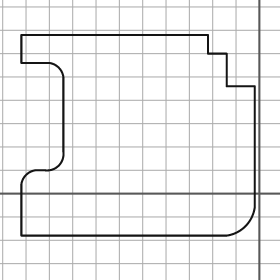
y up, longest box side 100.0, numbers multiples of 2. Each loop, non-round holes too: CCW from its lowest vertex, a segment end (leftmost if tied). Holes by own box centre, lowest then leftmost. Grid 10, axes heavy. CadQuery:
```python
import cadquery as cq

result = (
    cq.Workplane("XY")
    .moveTo(-102.0, -18.0)
    .lineTo(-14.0, -18.0)
    .threePointArc((-6.0, -14.0), (-2.0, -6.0))
    .lineTo(-2.0, 46.0)
    .lineTo(-14.0, 46.0)
    .lineTo(-14.0, 60.0)
    .lineTo(-22.0, 60.0)
    .lineTo(-22.0, 68.0)
    .lineTo(-102.0, 68.0)
    .lineTo(-102.0, 56.0)
    .lineTo(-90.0, 56.0)
    .threePointArc((-86.0, 54.0), (-84.0, 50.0))
    .lineTo(-84.0, 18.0)
    .threePointArc((-86.0, 12.0), (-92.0, 10.0))
    .lineTo(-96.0, 10.0)
    .threePointArc((-100.0, 8.0), (-102.0, 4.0))
    .close()
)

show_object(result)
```